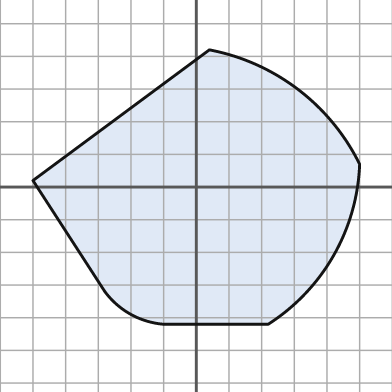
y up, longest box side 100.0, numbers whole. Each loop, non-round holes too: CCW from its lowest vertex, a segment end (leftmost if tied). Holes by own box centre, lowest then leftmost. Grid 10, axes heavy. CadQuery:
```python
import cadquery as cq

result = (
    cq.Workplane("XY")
    .moveTo(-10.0, -42.0)
    .lineTo(22.0, -42.0)
    .threePointArc((42.0, -21.0), (50.0, 7.0))
    .threePointArc((31.0, 30.0), (4.0, 42.0))
    .lineTo(-50.0, 2.0)
    .lineTo(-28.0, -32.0)
    .threePointArc((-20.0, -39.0), (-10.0, -42.0))
    .close()
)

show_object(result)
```